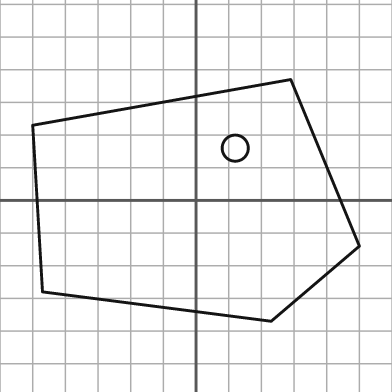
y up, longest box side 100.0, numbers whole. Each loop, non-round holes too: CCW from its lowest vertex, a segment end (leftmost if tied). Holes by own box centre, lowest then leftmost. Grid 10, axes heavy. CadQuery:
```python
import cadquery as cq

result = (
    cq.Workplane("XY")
    .moveTo(23.0, -37.0)
    .lineTo(50.0, -14.0)
    .lineTo(29.0, 37.0)
    .lineTo(-50.0, 23.0)
    .lineTo(-47.0, -28.0)
    .close()
    .moveTo(12.0, 16.0)
    .circle(4.0)
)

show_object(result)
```